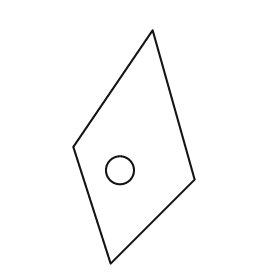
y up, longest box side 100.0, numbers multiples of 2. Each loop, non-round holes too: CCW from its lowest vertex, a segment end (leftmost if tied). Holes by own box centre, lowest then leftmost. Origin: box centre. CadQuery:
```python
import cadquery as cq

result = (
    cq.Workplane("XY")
    .moveTo(-10.0, -50.0)
    .lineTo(26.0, -14.0)
    .lineTo(8.0, 50.0)
    .lineTo(-26.0, 0.0)
    .close()
    .moveTo(-6.0, -10.0)
    .circle(6.0)
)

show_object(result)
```